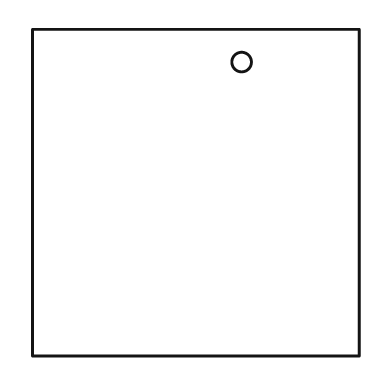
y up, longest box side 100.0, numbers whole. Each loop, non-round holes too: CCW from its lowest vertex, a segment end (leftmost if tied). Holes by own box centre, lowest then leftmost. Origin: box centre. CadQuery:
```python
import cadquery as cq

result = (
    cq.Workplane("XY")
    .moveTo(-50.0, -50.0)
    .lineTo(50.0, -50.0)
    .lineTo(50.0, 50.0)
    .lineTo(-50.0, 50.0)
    .close()
    .moveTo(14.0, 40.0)
    .circle(3.0)
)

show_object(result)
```